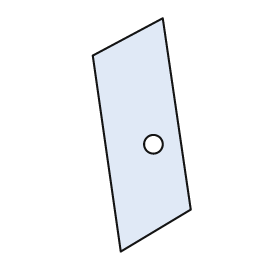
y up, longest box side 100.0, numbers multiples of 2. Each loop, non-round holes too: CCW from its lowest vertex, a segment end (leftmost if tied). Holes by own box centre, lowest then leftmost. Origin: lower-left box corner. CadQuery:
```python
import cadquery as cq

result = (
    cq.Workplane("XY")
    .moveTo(12.0, 0.0)
    .lineTo(42.0, 18.0)
    .lineTo(30.0, 100.0)
    .lineTo(0.0, 84.0)
    .close()
    .moveTo(26.0, 46.0)
    .circle(4.0)
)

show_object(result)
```